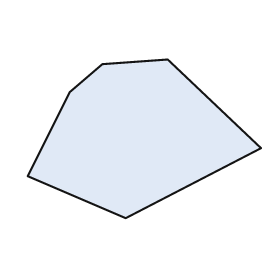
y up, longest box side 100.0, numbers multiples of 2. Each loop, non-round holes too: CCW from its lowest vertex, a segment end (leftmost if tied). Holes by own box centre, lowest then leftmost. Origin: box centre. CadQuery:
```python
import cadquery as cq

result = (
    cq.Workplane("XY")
    .moveTo(-8.0, -34.0)
    .lineTo(50.0, -4.0)
    .lineTo(10.0, 34.0)
    .lineTo(-18.0, 32.0)
    .lineTo(-32.0, 20.0)
    .lineTo(-50.0, -16.0)
    .close()
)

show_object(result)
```